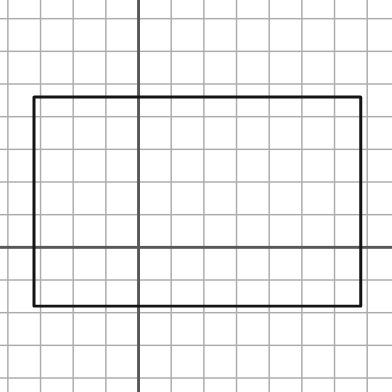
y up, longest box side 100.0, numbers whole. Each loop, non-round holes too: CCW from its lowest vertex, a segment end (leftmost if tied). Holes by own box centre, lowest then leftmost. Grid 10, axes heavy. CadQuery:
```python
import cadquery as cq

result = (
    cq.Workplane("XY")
    .moveTo(-32.0, -18.0)
    .lineTo(68.0, -18.0)
    .lineTo(68.0, 46.0)
    .lineTo(-32.0, 46.0)
    .close()
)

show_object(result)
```